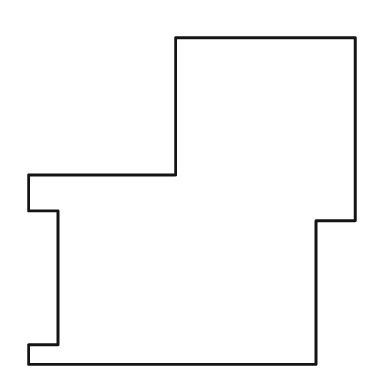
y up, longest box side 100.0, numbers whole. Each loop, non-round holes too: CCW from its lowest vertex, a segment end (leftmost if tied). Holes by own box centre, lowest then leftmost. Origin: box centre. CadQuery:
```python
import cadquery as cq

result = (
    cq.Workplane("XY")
    .moveTo(-50.0, -50.0)
    .lineTo(38.0, -50.0)
    .lineTo(38.0, -6.0)
    .lineTo(50.0, -6.0)
    .lineTo(50.0, 50.0)
    .lineTo(-5.0, 50.0)
    .lineTo(-5.0, 8.0)
    .lineTo(-50.0, 8.0)
    .lineTo(-50.0, -3.0)
    .lineTo(-41.0, -3.0)
    .lineTo(-41.0, -44.0)
    .lineTo(-50.0, -44.0)
    .close()
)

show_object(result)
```